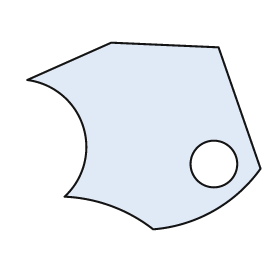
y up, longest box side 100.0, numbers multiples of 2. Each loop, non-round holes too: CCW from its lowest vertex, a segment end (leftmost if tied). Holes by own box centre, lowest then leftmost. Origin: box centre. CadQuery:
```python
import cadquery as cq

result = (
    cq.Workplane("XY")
    .moveTo(4.0, -40.0)
    .threePointArc((30.0, -32.0), (50.0, -14.0))
    .lineTo(32.0, 38.0)
    .lineTo(-14.0, 40.0)
    .lineTo(-50.0, 24.0)
    .threePointArc((-26.0, 4.0), (-34.0, -26.0))
    .threePointArc((-14.0, -30.0), (4.0, -40.0))
    .close()
    .moveTo(30.0, -12.0)
    .circle(10.0)
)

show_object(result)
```